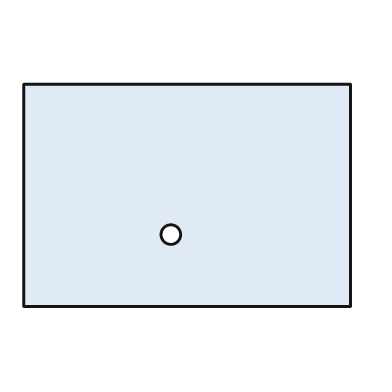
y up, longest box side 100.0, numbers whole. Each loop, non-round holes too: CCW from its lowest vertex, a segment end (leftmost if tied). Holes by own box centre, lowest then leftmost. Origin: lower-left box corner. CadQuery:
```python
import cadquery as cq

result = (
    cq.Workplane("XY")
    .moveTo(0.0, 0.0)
    .lineTo(100.0, 0.0)
    .lineTo(100.0, 68.0)
    .lineTo(0.0, 68.0)
    .close()
    .moveTo(45.0, 22.0)
    .circle(3.0)
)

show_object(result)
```